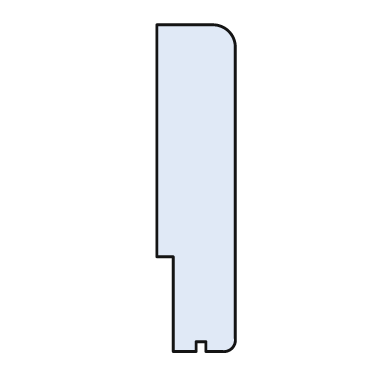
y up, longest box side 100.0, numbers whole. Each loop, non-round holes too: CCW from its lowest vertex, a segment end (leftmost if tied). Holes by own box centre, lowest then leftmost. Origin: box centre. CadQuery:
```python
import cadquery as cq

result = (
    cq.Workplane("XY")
    .moveTo(-7.0, -50.0)
    .lineTo(0.0, -50.0)
    .lineTo(0.0, -47.0)
    .lineTo(3.0, -47.0)
    .lineTo(3.0, -50.0)
    .lineTo(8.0, -50.0)
    .threePointArc((11.0, -49.0), (12.0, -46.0))
    .lineTo(12.0, 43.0)
    .threePointArc((10.0, 48.0), (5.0, 50.0))
    .lineTo(-12.0, 50.0)
    .lineTo(-12.0, -21.0)
    .lineTo(-7.0, -21.0)
    .close()
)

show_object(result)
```